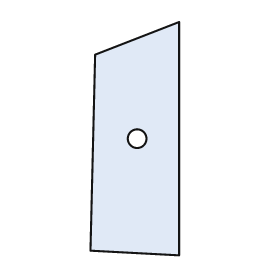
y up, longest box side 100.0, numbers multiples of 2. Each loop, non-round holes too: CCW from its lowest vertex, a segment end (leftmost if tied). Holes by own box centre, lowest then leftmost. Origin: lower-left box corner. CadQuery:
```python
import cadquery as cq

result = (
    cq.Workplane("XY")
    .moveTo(38.0, 0.0)
    .lineTo(38.0, 100.0)
    .lineTo(2.0, 86.0)
    .lineTo(0.0, 2.0)
    .close()
    .moveTo(20.0, 50.0)
    .circle(4.0)
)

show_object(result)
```